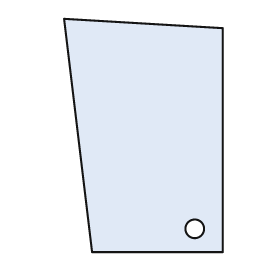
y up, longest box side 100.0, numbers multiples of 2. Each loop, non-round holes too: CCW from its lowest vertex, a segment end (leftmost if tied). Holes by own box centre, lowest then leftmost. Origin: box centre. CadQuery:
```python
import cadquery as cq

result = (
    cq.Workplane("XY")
    .moveTo(-22.0, -50.0)
    .lineTo(34.0, -50.0)
    .lineTo(34.0, 46.0)
    .lineTo(-34.0, 50.0)
    .close()
    .moveTo(22.0, -40.0)
    .circle(4.0)
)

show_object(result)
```